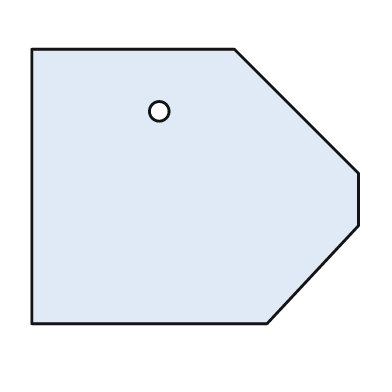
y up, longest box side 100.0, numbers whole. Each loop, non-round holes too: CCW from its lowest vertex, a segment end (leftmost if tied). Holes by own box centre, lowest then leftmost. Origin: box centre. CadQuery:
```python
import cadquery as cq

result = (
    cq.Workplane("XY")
    .moveTo(-50.0, -42.0)
    .lineTo(22.0, -42.0)
    .lineTo(50.0, -12.0)
    .lineTo(50.0, 4.0)
    .lineTo(12.0, 42.0)
    .lineTo(-50.0, 42.0)
    .close()
    .moveTo(-11.0, 23.0)
    .circle(3.0)
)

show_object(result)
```